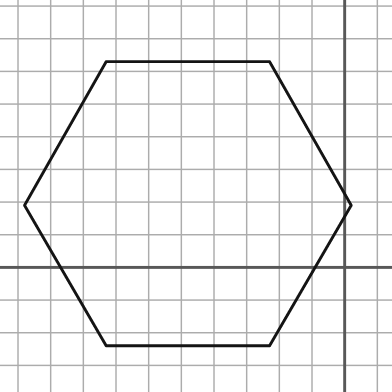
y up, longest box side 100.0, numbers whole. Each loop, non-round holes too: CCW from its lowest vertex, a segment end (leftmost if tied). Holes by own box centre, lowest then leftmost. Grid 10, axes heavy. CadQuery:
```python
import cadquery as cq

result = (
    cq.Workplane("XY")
    .moveTo(-73.0, -24.0)
    .lineTo(-23.0, -24.0)
    .lineTo(2.0, 19.0)
    .lineTo(-23.0, 63.0)
    .lineTo(-73.0, 63.0)
    .lineTo(-98.0, 19.0)
    .close()
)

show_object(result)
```